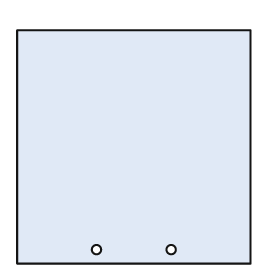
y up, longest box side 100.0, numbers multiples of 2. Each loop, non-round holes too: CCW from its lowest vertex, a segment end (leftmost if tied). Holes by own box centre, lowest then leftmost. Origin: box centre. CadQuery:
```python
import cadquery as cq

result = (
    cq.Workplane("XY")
    .moveTo(-50.0, -50.0)
    .lineTo(50.0, -50.0)
    .lineTo(50.0, 50.0)
    .lineTo(-50.0, 50.0)
    .close()
    .moveTo(-16.0, -44.0)
    .circle(2.0)
    .moveTo(16.0, -44.0)
    .circle(2.0)
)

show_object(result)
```